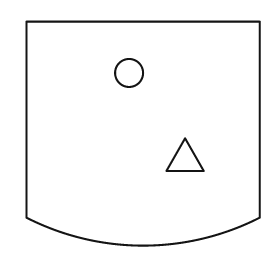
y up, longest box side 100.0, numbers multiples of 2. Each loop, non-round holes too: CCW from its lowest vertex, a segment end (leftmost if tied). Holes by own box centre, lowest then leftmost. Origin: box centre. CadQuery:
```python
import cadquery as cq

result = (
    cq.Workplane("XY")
    .moveTo(-50.0, -36.0)
    .threePointArc((0.0, -48.0), (50.0, -36.0))
    .lineTo(50.0, 48.0)
    .lineTo(-50.0, 48.0)
    .close()
    .moveTo(10.0, -16.0)
    .lineTo(26.0, -16.0)
    .lineTo(18.0, -2.0)
    .close()
    .moveTo(-6.0, 26.0)
    .circle(6.0)
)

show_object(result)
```